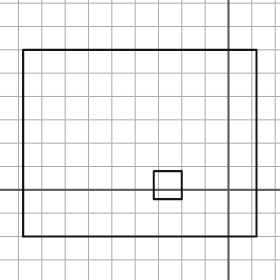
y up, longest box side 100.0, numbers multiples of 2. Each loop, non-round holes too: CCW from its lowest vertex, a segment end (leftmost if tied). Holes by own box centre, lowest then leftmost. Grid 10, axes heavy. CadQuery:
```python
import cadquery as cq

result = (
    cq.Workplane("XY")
    .moveTo(-88.0, -20.0)
    .lineTo(12.0, -20.0)
    .lineTo(12.0, 60.0)
    .lineTo(-88.0, 60.0)
    .close()
    .moveTo(-32.0, -4.0)
    .lineTo(-20.0, -4.0)
    .lineTo(-20.0, 8.0)
    .lineTo(-32.0, 8.0)
    .close()
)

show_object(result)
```